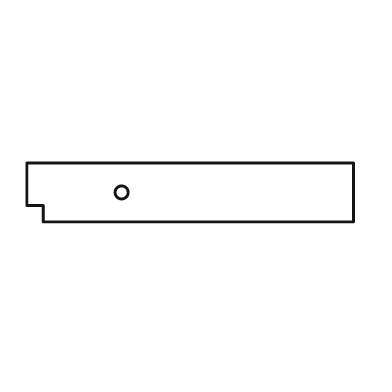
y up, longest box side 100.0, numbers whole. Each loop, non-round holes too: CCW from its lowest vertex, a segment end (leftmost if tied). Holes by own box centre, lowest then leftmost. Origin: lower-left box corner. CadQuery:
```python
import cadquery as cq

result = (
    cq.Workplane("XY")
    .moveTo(5.0, 0.0)
    .lineTo(100.0, 0.0)
    .lineTo(100.0, 18.0)
    .lineTo(0.0, 18.0)
    .lineTo(0.0, 5.0)
    .lineTo(5.0, 5.0)
    .close()
    .moveTo(29.0, 9.0)
    .circle(2.0)
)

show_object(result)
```